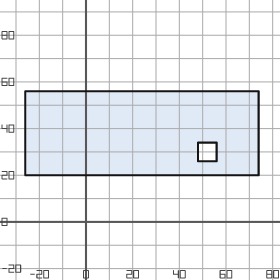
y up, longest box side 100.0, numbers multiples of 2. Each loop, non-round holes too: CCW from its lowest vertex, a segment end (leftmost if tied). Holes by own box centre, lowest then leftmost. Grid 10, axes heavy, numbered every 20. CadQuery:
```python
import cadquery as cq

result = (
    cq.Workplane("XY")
    .moveTo(-26.0, 20.0)
    .lineTo(74.0, 20.0)
    .lineTo(74.0, 56.0)
    .lineTo(-26.0, 56.0)
    .close()
    .moveTo(48.0, 26.0)
    .lineTo(56.0, 26.0)
    .lineTo(56.0, 34.0)
    .lineTo(48.0, 34.0)
    .close()
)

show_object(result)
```